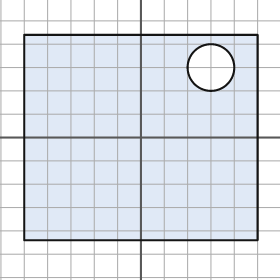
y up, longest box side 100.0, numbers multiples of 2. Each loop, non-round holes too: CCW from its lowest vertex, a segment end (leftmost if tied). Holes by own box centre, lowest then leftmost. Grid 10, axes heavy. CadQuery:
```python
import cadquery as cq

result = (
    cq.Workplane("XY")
    .moveTo(-50.0, -44.0)
    .lineTo(50.0, -44.0)
    .lineTo(50.0, 44.0)
    .lineTo(-50.0, 44.0)
    .close()
    .moveTo(30.0, 30.0)
    .circle(10.0)
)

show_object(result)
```